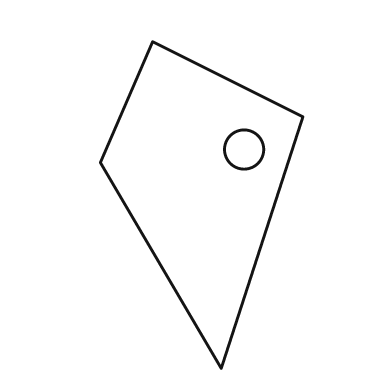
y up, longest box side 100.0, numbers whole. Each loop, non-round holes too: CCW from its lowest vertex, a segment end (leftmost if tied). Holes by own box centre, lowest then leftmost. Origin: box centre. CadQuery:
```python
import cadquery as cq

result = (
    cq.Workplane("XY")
    .moveTo(6.0, -50.0)
    .lineTo(31.0, 27.0)
    .lineTo(-15.0, 50.0)
    .lineTo(-31.0, 13.0)
    .close()
    .moveTo(13.0, 17.0)
    .circle(6.0)
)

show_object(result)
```